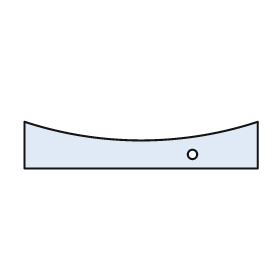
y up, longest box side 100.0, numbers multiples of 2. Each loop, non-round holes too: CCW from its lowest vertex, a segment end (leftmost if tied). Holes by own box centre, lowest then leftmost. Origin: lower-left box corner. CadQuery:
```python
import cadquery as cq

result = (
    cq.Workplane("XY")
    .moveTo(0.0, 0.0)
    .lineTo(100.0, 0.0)
    .lineTo(100.0, 20.0)
    .threePointArc((50.0, 12.0), (0.0, 20.0))
    .close()
    .moveTo(72.0, 6.0)
    .circle(2.0)
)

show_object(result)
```